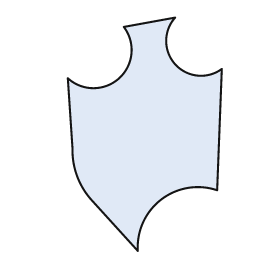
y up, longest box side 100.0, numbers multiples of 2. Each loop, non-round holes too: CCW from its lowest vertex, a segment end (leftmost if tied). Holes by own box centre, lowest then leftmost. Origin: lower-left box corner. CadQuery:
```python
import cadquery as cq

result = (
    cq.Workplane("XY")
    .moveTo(30.0, 0.0)
    .threePointArc((40.0, 22.0), (64.0, 26.0))
    .lineTo(66.0, 78.0)
    .threePointArc((46.0, 80.0), (46.0, 100.0))
    .lineTo(24.0, 96.0)
    .threePointArc((22.0, 74.0), (0.0, 74.0))
    .lineTo(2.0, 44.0)
    .threePointArc((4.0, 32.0), (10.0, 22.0))
    .close()
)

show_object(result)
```